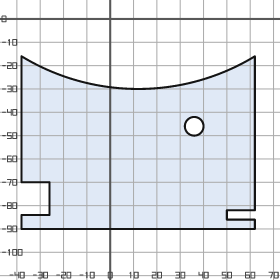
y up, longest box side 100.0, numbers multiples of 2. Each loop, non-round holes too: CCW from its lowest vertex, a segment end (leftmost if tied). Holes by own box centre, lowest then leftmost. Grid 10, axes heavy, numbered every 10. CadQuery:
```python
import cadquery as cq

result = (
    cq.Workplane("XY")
    .moveTo(-38.0, -90.0)
    .lineTo(62.0, -90.0)
    .lineTo(62.0, -86.0)
    .lineTo(50.0, -86.0)
    .lineTo(50.0, -82.0)
    .lineTo(62.0, -82.0)
    .lineTo(62.0, -16.0)
    .threePointArc((12.0, -30.0), (-38.0, -16.0))
    .lineTo(-38.0, -70.0)
    .lineTo(-26.0, -70.0)
    .lineTo(-26.0, -84.0)
    .lineTo(-38.0, -84.0)
    .close()
    .moveTo(36.0, -46.0)
    .circle(4.0)
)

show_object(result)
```